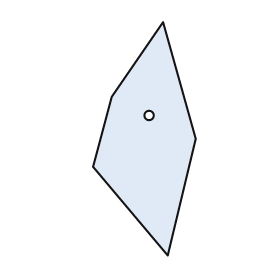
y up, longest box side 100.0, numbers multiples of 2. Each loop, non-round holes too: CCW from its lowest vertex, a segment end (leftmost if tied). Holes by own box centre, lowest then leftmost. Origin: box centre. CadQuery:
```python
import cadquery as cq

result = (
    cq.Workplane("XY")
    .moveTo(10.0, -50.0)
    .lineTo(22.0, 0.0)
    .lineTo(8.0, 50.0)
    .lineTo(-14.0, 18.0)
    .lineTo(-22.0, -12.0)
    .close()
    .moveTo(2.0, 10.0)
    .circle(2.0)
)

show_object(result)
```